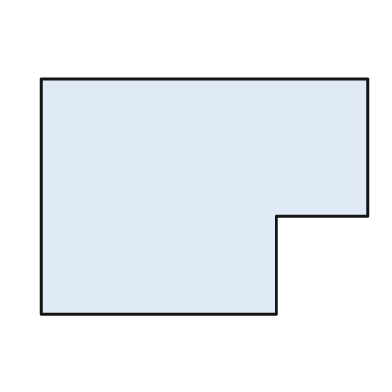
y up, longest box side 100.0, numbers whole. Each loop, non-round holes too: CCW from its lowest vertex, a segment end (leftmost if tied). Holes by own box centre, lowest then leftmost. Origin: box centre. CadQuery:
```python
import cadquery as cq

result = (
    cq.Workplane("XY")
    .moveTo(-50.0, -36.0)
    .lineTo(22.0, -36.0)
    .lineTo(22.0, -6.0)
    .lineTo(50.0, -6.0)
    .lineTo(50.0, 36.0)
    .lineTo(-50.0, 36.0)
    .close()
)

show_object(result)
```